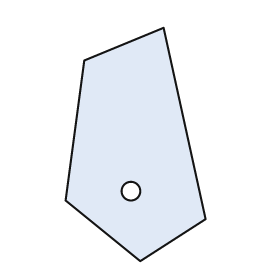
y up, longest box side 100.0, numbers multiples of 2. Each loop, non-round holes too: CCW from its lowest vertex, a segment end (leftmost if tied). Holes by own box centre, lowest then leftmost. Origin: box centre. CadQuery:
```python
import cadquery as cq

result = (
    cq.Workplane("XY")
    .moveTo(2.0, -50.0)
    .lineTo(30.0, -32.0)
    .lineTo(12.0, 50.0)
    .lineTo(-22.0, 36.0)
    .lineTo(-30.0, -24.0)
    .close()
    .moveTo(-2.0, -20.0)
    .circle(4.0)
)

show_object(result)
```